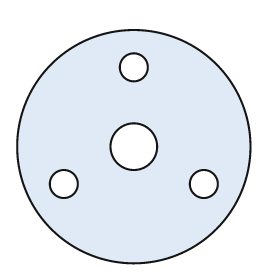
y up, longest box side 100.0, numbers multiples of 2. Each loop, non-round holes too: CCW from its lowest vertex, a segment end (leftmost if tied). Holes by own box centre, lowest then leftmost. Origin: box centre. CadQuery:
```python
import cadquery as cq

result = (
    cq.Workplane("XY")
    .moveTo(0.0, 0.0)
    .circle(50.0)
    .moveTo(-30.0, -16.0)
    .circle(6.0)
    .moveTo(30.0, -16.0)
    .circle(6.0)
    .moveTo(0.0, 0.0)
    .circle(10.0)
    .moveTo(0.0, 34.0)
    .circle(6.0)
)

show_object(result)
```